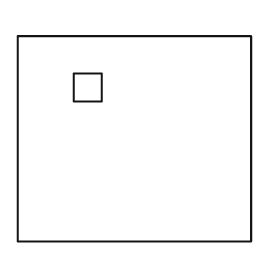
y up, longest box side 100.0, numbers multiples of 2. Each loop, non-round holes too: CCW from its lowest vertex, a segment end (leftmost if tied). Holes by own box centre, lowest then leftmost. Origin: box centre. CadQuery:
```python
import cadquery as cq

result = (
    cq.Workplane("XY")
    .moveTo(-50.0, -44.0)
    .lineTo(50.0, -44.0)
    .lineTo(50.0, 44.0)
    .lineTo(-50.0, 44.0)
    .close()
    .moveTo(-26.0, 16.0)
    .lineTo(-14.0, 16.0)
    .lineTo(-14.0, 28.0)
    .lineTo(-26.0, 28.0)
    .close()
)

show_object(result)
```